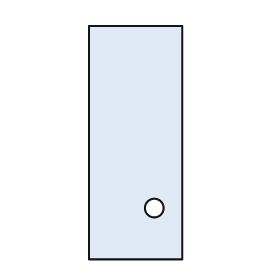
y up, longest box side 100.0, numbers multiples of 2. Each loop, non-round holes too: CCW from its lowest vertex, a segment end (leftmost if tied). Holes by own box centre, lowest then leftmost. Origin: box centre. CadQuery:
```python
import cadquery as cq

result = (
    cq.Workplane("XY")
    .moveTo(-20.0, -50.0)
    .lineTo(20.0, -50.0)
    .lineTo(20.0, 50.0)
    .lineTo(-20.0, 50.0)
    .close()
    .moveTo(8.0, -28.0)
    .circle(4.0)
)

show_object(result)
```